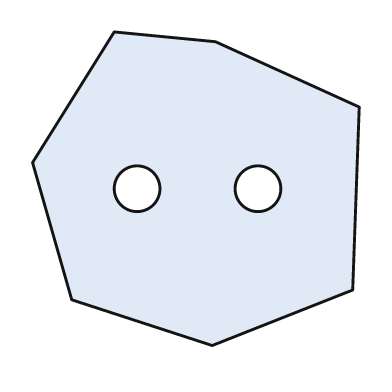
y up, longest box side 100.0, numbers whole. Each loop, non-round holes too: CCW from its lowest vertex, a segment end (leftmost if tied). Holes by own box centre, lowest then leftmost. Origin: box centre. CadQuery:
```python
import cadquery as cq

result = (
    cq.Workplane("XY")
    .moveTo(5.0, -48.0)
    .lineTo(48.0, -31.0)
    .lineTo(50.0, 25.0)
    .lineTo(6.0, 45.0)
    .lineTo(-25.0, 48.0)
    .lineTo(-50.0, 8.0)
    .lineTo(-38.0, -34.0)
    .close()
    .moveTo(-18.0, 0.0)
    .circle(7.0)
    .moveTo(19.0, 0.0)
    .circle(7.0)
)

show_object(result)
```